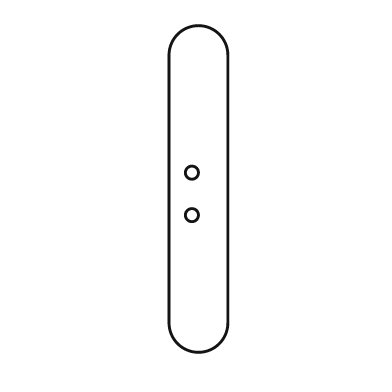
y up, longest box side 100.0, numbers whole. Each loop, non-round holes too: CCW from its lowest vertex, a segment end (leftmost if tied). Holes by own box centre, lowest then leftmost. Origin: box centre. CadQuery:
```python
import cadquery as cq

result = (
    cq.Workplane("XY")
    .moveTo(-9.0, -41.0)
    .threePointArc((0.0, -50.0), (9.0, -41.0))
    .lineTo(9.0, 41.0)
    .threePointArc((0.0, 50.0), (-9.0, 41.0))
    .close()
    .moveTo(-2.0, -8.0)
    .circle(2.0)
    .moveTo(-2.0, 5.0)
    .circle(2.0)
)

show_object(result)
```